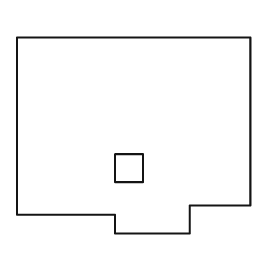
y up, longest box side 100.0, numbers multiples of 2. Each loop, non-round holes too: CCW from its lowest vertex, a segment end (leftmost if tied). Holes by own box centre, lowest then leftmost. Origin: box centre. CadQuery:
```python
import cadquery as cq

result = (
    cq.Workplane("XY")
    .moveTo(-8.0, -42.0)
    .lineTo(24.0, -42.0)
    .lineTo(24.0, -30.0)
    .lineTo(50.0, -30.0)
    .lineTo(50.0, 42.0)
    .lineTo(-50.0, 42.0)
    .lineTo(-50.0, -34.0)
    .lineTo(-8.0, -34.0)
    .close()
    .moveTo(-8.0, -20.0)
    .lineTo(4.0, -20.0)
    .lineTo(4.0, -8.0)
    .lineTo(-8.0, -8.0)
    .close()
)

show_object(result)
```